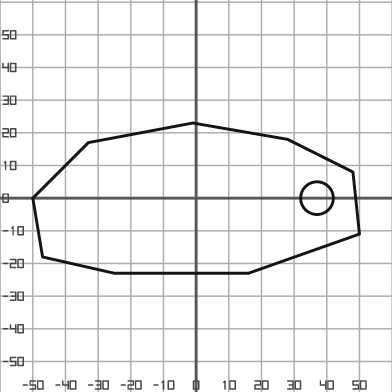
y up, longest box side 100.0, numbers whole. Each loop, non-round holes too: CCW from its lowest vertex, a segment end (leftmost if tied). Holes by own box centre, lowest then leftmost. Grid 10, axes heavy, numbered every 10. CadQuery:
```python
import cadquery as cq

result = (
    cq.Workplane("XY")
    .moveTo(-25.0, -23.0)
    .lineTo(16.0, -23.0)
    .lineTo(50.0, -11.0)
    .lineTo(48.0, 8.0)
    .lineTo(28.0, 18.0)
    .lineTo(-1.0, 23.0)
    .lineTo(-33.0, 17.0)
    .lineTo(-50.0, 0.0)
    .lineTo(-47.0, -18.0)
    .close()
    .moveTo(37.0, 0.0)
    .circle(5.0)
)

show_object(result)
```